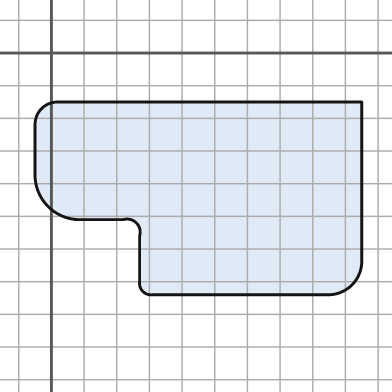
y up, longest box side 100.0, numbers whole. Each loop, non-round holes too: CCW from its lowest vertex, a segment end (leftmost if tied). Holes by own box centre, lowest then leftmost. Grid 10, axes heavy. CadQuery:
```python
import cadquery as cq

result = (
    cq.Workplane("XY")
    .moveTo(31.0, -74.0)
    .lineTo(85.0, -74.0)
    .threePointArc((92.0, -71.0), (95.0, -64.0))
    .lineTo(95.0, -15.0)
    .lineTo(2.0, -15.0)
    .threePointArc((-3.0, -17.0), (-5.0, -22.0))
    .lineTo(-5.0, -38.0)
    .threePointArc((-1.0, -47.0), (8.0, -51.0))
    .lineTo(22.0, -51.0)
    .threePointArc((26.0, -52.0), (27.0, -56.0))
    .lineTo(27.0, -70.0)
    .threePointArc((28.0, -73.0), (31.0, -74.0))
    .close()
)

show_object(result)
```